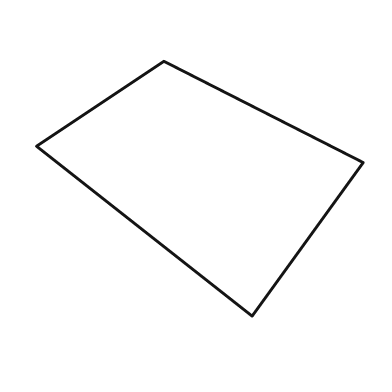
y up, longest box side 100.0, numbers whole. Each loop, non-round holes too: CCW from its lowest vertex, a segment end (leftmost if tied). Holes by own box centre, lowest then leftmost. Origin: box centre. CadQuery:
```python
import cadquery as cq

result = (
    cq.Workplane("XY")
    .moveTo(16.0, -39.0)
    .lineTo(50.0, 8.0)
    .lineTo(-11.0, 39.0)
    .lineTo(-50.0, 13.0)
    .close()
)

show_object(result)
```